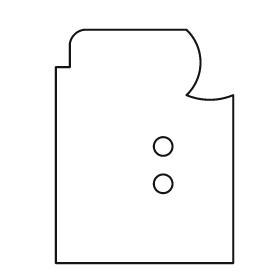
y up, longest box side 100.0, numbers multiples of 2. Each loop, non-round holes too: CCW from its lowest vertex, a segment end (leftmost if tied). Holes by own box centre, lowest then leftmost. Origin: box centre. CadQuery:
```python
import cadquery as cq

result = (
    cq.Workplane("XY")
    .moveTo(-38.0, -50.0)
    .lineTo(38.0, -50.0)
    .lineTo(38.0, 22.0)
    .threePointArc((28.0, 20.0), (18.0, 22.0))
    .threePointArc((24.0, 36.0), (18.0, 50.0))
    .lineTo(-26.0, 50.0)
    .threePointArc((-30.0, 48.0), (-32.0, 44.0))
    .lineTo(-32.0, 34.0)
    .lineTo(-38.0, 34.0)
    .close()
    .moveTo(8.0, -16.0)
    .circle(4.0)
    .moveTo(8.0, 0.0)
    .circle(4.0)
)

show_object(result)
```